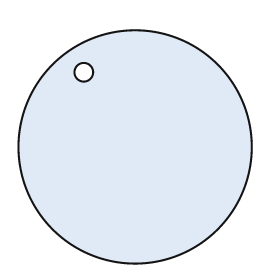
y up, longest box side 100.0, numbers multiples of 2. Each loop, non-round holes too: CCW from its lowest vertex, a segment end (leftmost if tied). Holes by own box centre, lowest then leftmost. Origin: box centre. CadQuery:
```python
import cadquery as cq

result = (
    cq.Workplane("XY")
    .moveTo(0.0, 0.0)
    .circle(50.0)
    .moveTo(-22.0, 32.0)
    .circle(4.0)
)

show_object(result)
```